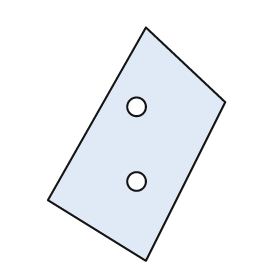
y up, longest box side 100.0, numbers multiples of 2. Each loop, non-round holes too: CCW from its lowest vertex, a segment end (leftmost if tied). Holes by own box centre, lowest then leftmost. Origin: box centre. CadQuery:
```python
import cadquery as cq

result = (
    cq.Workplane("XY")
    .moveTo(4.0, -50.0)
    .lineTo(38.0, 18.0)
    .lineTo(4.0, 50.0)
    .lineTo(-38.0, -24.0)
    .close()
    .moveTo(0.0, -16.0)
    .circle(4.0)
    .moveTo(0.0, 16.0)
    .circle(4.0)
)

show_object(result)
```